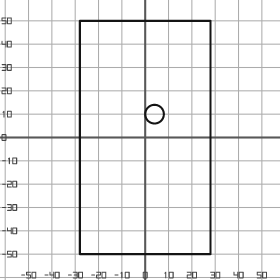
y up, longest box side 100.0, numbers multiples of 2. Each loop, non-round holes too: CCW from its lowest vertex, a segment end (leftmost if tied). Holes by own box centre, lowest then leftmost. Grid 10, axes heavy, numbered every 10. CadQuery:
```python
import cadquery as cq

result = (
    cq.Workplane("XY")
    .moveTo(-28.0, -50.0)
    .lineTo(28.0, -50.0)
    .lineTo(28.0, 50.0)
    .lineTo(-28.0, 50.0)
    .close()
    .moveTo(4.0, 10.0)
    .circle(4.0)
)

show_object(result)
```